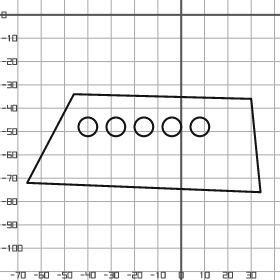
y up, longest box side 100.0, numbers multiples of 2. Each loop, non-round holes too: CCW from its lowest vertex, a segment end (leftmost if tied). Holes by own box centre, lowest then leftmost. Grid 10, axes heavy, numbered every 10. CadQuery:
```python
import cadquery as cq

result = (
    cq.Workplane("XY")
    .moveTo(34.0, -76.0)
    .lineTo(30.0, -36.0)
    .lineTo(-46.0, -34.0)
    .lineTo(-66.0, -72.0)
    .close()
    .moveTo(-40.0, -48.0)
    .circle(4.0)
    .moveTo(-28.0, -48.0)
    .circle(4.0)
    .moveTo(-16.0, -48.0)
    .circle(4.0)
    .moveTo(-4.0, -48.0)
    .circle(4.0)
    .moveTo(8.0, -48.0)
    .circle(4.0)
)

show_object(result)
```